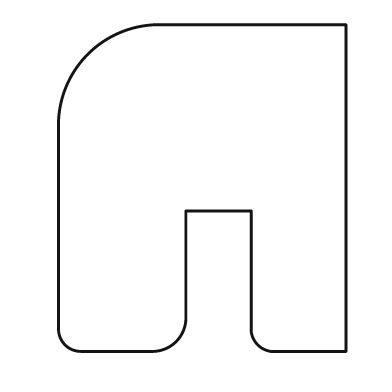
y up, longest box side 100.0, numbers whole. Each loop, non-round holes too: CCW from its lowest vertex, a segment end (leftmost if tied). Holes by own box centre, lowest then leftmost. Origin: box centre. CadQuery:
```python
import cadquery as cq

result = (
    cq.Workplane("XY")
    .moveTo(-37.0, -50.0)
    .lineTo(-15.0, -50.0)
    .threePointArc((-8.0, -47.0), (-5.0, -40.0))
    .lineTo(-5.0, -7.0)
    .lineTo(15.0, -7.0)
    .lineTo(15.0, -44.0)
    .threePointArc((17.0, -48.0), (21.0, -50.0))
    .lineTo(44.0, -50.0)
    .lineTo(44.0, 50.0)
    .lineTo(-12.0, 50.0)
    .threePointArc((-35.0, 41.0), (-44.0, 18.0))
    .lineTo(-44.0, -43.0)
    .threePointArc((-42.0, -48.0), (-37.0, -50.0))
    .close()
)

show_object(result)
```